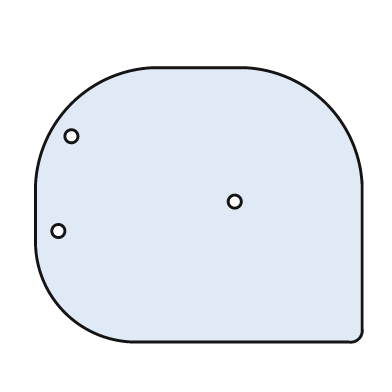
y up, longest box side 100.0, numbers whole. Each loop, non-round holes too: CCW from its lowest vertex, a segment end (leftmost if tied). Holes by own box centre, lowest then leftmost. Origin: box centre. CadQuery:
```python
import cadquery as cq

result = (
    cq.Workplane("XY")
    .moveTo(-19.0, -42.0)
    .lineTo(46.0, -42.0)
    .threePointArc((49.0, -41.0), (50.0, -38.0))
    .lineTo(50.0, 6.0)
    .threePointArc((39.0, 31.0), (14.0, 42.0))
    .lineTo(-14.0, 42.0)
    .threePointArc((-39.0, 31.0), (-50.0, 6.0))
    .lineTo(-50.0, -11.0)
    .threePointArc((-41.0, -33.0), (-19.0, -42.0))
    .close()
    .moveTo(-43.0, -8.0)
    .circle(2.0)
    .moveTo(11.0, 1.0)
    .circle(2.0)
    .moveTo(-39.0, 21.0)
    .circle(2.0)
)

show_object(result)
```